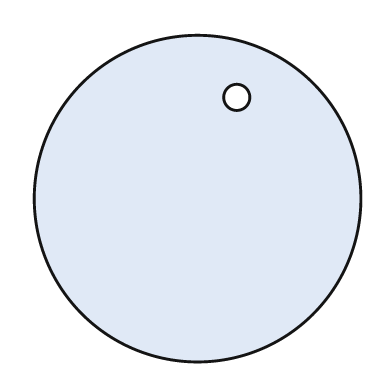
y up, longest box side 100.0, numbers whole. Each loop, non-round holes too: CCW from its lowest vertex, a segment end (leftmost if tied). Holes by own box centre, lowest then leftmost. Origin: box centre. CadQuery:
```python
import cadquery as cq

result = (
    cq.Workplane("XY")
    .moveTo(0.0, 0.0)
    .circle(50.0)
    .moveTo(12.0, 31.0)
    .circle(4.0)
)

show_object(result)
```